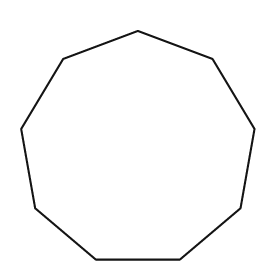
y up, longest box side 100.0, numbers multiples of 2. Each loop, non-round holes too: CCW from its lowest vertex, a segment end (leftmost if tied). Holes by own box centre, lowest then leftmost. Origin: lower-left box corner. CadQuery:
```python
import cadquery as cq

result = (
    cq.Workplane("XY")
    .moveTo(32.0, 0.0)
    .lineTo(68.0, 0.0)
    .lineTo(94.0, 22.0)
    .lineTo(100.0, 56.0)
    .lineTo(82.0, 86.0)
    .lineTo(50.0, 98.0)
    .lineTo(18.0, 86.0)
    .lineTo(0.0, 56.0)
    .lineTo(6.0, 22.0)
    .close()
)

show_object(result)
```